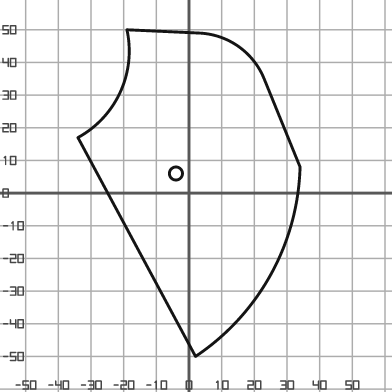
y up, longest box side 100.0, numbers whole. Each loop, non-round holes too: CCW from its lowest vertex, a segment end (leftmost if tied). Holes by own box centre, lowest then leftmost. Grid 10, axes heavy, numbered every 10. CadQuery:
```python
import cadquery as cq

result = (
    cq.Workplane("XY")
    .moveTo(2.0, -50.0)
    .threePointArc((25.0, -25.0), (34.0, 8.0))
    .lineTo(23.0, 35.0)
    .threePointArc((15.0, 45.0), (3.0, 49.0))
    .lineTo(-19.0, 50.0)
    .threePointArc((-21.0, 31.0), (-34.0, 17.0))
    .close()
    .moveTo(-4.0, 6.0)
    .circle(2.0)
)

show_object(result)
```